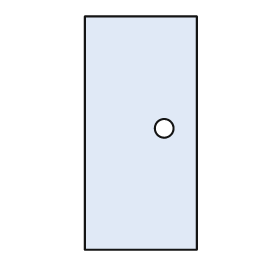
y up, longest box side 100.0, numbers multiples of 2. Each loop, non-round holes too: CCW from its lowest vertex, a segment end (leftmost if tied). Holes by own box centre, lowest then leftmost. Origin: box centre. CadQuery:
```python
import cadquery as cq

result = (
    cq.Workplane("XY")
    .moveTo(-24.0, -50.0)
    .lineTo(24.0, -50.0)
    .lineTo(24.0, 50.0)
    .lineTo(-24.0, 50.0)
    .close()
    .moveTo(10.0, 2.0)
    .circle(4.0)
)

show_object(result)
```